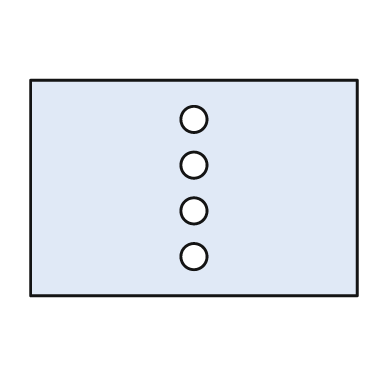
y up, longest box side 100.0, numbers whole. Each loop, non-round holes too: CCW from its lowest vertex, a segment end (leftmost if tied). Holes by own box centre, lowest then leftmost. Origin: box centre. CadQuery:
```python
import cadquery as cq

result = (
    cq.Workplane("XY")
    .moveTo(-50.0, -33.0)
    .lineTo(50.0, -33.0)
    .lineTo(50.0, 33.0)
    .lineTo(-50.0, 33.0)
    .close()
    .moveTo(0.0, -21.0)
    .circle(4.0)
    .moveTo(0.0, -7.0)
    .circle(4.0)
    .moveTo(0.0, 7.0)
    .circle(4.0)
    .moveTo(0.0, 21.0)
    .circle(4.0)
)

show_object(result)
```